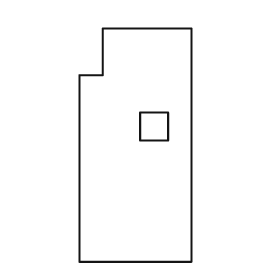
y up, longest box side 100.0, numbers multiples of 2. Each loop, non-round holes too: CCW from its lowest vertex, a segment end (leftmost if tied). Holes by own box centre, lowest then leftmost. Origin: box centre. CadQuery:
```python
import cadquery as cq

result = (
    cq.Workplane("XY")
    .moveTo(-24.0, -50.0)
    .lineTo(24.0, -50.0)
    .lineTo(24.0, 50.0)
    .lineTo(-14.0, 50.0)
    .lineTo(-14.0, 30.0)
    .lineTo(-24.0, 30.0)
    .close()
    .moveTo(2.0, 2.0)
    .lineTo(14.0, 2.0)
    .lineTo(14.0, 14.0)
    .lineTo(2.0, 14.0)
    .close()
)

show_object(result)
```